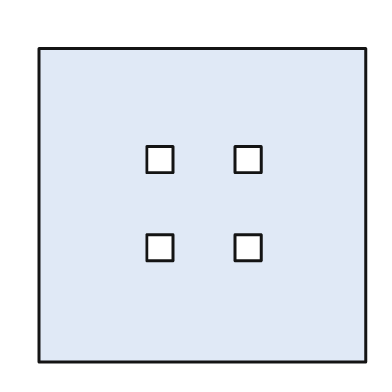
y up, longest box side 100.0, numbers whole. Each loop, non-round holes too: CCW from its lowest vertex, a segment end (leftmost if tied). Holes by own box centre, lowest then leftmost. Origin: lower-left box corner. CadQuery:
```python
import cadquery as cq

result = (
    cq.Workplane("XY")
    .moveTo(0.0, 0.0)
    .lineTo(100.0, 0.0)
    .lineTo(100.0, 96.0)
    .lineTo(0.0, 96.0)
    .close()
    .moveTo(33.0, 31.0)
    .lineTo(41.0, 31.0)
    .lineTo(41.0, 39.0)
    .lineTo(33.0, 39.0)
    .close()
    .moveTo(60.0, 31.0)
    .lineTo(68.0, 31.0)
    .lineTo(68.0, 39.0)
    .lineTo(60.0, 39.0)
    .close()
    .moveTo(33.0, 58.0)
    .lineTo(41.0, 58.0)
    .lineTo(41.0, 66.0)
    .lineTo(33.0, 66.0)
    .close()
    .moveTo(60.0, 58.0)
    .lineTo(68.0, 58.0)
    .lineTo(68.0, 66.0)
    .lineTo(60.0, 66.0)
    .close()
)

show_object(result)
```